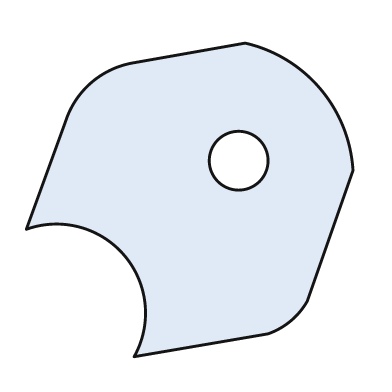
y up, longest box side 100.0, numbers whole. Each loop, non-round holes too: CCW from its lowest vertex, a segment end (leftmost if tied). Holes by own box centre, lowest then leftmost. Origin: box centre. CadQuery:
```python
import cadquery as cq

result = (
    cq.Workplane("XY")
    .moveTo(-17.0, -48.0)
    .lineTo(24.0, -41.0)
    .threePointArc((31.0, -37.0), (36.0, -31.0))
    .lineTo(50.0, 9.0)
    .threePointArc((40.0, 34.0), (17.0, 48.0))
    .lineTo(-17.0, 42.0)
    .threePointArc((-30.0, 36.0), (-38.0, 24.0))
    .lineTo(-50.0, -9.0)
    .threePointArc((-20.0, -17.0), (-17.0, -48.0))
    .close()
    .moveTo(15.0, 12.0)
    .circle(9.0)
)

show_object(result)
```